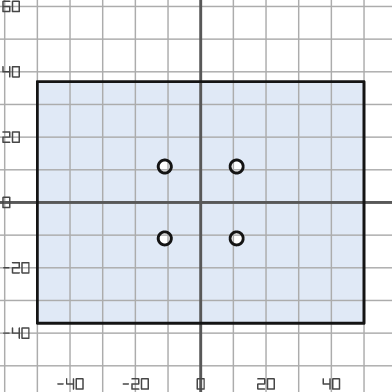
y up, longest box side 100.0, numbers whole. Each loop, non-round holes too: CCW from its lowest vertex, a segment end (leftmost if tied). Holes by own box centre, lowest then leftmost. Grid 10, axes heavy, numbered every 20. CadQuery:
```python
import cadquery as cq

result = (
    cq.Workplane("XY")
    .moveTo(-50.0, -37.0)
    .lineTo(50.0, -37.0)
    .lineTo(50.0, 37.0)
    .lineTo(-50.0, 37.0)
    .close()
    .moveTo(-11.0, -11.0)
    .circle(2.0)
    .moveTo(11.0, -11.0)
    .circle(2.0)
    .moveTo(-11.0, 11.0)
    .circle(2.0)
    .moveTo(11.0, 11.0)
    .circle(2.0)
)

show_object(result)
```